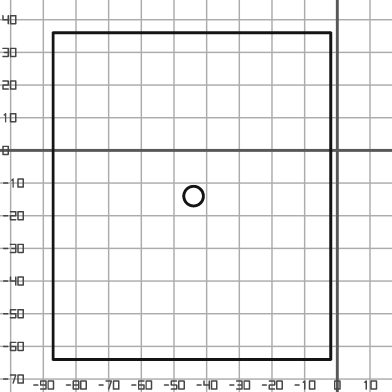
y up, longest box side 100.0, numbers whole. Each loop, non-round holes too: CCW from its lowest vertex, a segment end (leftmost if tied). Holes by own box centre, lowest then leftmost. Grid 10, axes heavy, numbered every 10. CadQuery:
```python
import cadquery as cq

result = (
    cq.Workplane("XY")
    .moveTo(-87.0, -64.0)
    .lineTo(-2.0, -64.0)
    .lineTo(-2.0, 36.0)
    .lineTo(-87.0, 36.0)
    .close()
    .moveTo(-44.0, -14.0)
    .circle(3.0)
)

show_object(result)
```